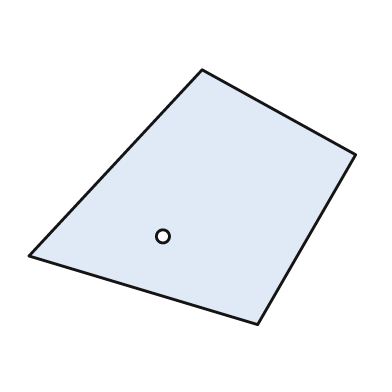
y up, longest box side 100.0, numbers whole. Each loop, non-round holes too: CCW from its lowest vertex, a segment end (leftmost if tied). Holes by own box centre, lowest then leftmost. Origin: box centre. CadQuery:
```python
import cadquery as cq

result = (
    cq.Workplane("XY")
    .moveTo(20.0, -39.0)
    .lineTo(50.0, 13.0)
    .lineTo(3.0, 39.0)
    .lineTo(-50.0, -18.0)
    .close()
    .moveTo(-9.0, -12.0)
    .circle(2.0)
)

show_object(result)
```